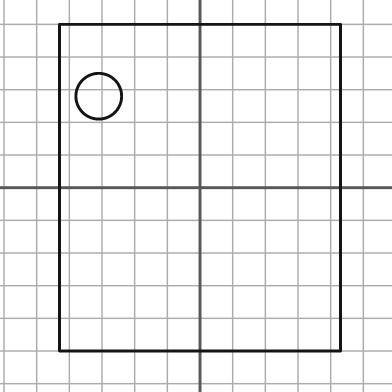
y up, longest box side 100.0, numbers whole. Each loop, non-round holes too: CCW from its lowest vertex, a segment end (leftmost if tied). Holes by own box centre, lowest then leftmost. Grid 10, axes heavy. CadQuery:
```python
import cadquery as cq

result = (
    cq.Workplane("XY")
    .moveTo(-43.0, -50.0)
    .lineTo(43.0, -50.0)
    .lineTo(43.0, 50.0)
    .lineTo(-43.0, 50.0)
    .close()
    .moveTo(-31.0, 28.0)
    .circle(7.0)
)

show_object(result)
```